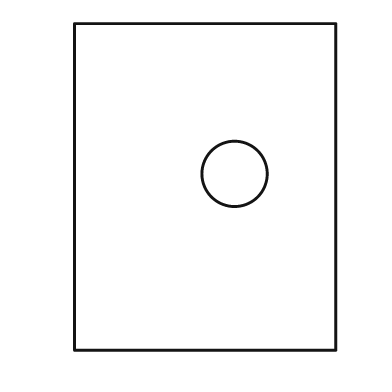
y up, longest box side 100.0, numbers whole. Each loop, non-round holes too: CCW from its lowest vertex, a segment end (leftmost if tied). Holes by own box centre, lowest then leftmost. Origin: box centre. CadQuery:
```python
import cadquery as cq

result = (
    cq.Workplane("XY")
    .moveTo(-40.0, -50.0)
    .lineTo(40.0, -50.0)
    .lineTo(40.0, 50.0)
    .lineTo(-40.0, 50.0)
    .close()
    .moveTo(9.0, 4.0)
    .circle(10.0)
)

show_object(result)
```